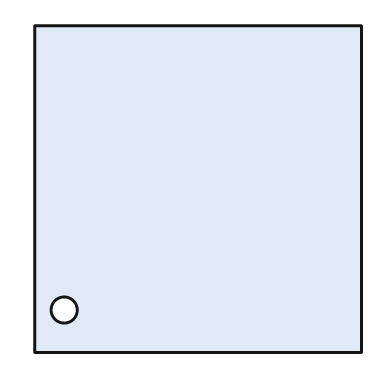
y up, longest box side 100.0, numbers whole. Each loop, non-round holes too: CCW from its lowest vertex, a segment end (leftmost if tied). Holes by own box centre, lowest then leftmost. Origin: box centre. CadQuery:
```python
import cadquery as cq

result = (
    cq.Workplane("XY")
    .moveTo(-50.0, -50.0)
    .lineTo(50.0, -50.0)
    .lineTo(50.0, 50.0)
    .lineTo(-50.0, 50.0)
    .close()
    .moveTo(-41.0, -37.0)
    .circle(4.0)
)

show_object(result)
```